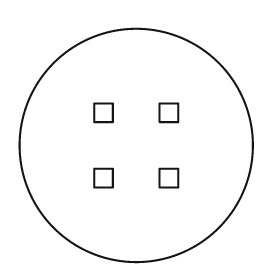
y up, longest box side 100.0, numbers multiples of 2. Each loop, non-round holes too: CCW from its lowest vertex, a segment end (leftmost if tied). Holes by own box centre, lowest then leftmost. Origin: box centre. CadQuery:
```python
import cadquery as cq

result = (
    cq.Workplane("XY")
    .moveTo(0.0, 0.0)
    .circle(50.0)
    .moveTo(-18.0, -18.0)
    .lineTo(-10.0, -18.0)
    .lineTo(-10.0, -10.0)
    .lineTo(-18.0, -10.0)
    .close()
    .moveTo(10.0, -18.0)
    .lineTo(18.0, -18.0)
    .lineTo(18.0, -10.0)
    .lineTo(10.0, -10.0)
    .close()
    .moveTo(-18.0, 10.0)
    .lineTo(-10.0, 10.0)
    .lineTo(-10.0, 18.0)
    .lineTo(-18.0, 18.0)
    .close()
    .moveTo(10.0, 10.0)
    .lineTo(18.0, 10.0)
    .lineTo(18.0, 18.0)
    .lineTo(10.0, 18.0)
    .close()
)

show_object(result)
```